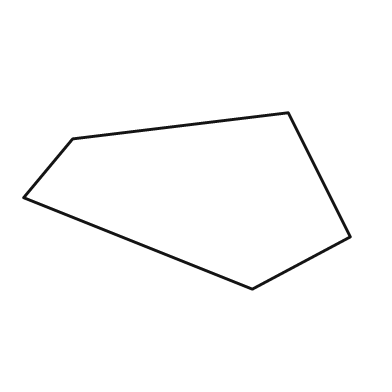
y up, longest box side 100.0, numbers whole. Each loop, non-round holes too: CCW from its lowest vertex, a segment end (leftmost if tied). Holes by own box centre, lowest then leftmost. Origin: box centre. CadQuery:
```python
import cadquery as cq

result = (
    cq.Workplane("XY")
    .moveTo(20.0, -27.0)
    .lineTo(50.0, -11.0)
    .lineTo(31.0, 27.0)
    .lineTo(-35.0, 19.0)
    .lineTo(-50.0, 1.0)
    .close()
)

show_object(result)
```